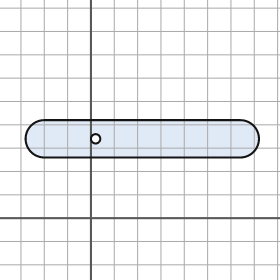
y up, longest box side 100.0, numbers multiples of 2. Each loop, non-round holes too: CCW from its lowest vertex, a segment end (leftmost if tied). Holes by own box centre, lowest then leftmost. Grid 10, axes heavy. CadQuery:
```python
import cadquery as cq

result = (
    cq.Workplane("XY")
    .moveTo(-20.0, 26.0)
    .lineTo(64.0, 26.0)
    .threePointArc((72.0, 34.0), (64.0, 42.0))
    .lineTo(-20.0, 42.0)
    .threePointArc((-28.0, 34.0), (-20.0, 26.0))
    .close()
    .moveTo(2.0, 34.0)
    .circle(2.0)
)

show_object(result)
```